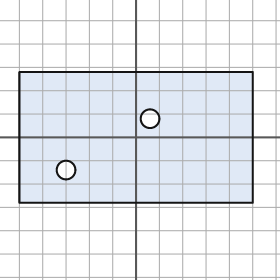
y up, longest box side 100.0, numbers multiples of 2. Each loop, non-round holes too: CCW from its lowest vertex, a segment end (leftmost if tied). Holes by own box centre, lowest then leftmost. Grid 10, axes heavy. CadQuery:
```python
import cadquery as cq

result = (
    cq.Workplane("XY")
    .moveTo(-50.0, -28.0)
    .lineTo(50.0, -28.0)
    .lineTo(50.0, 28.0)
    .lineTo(-50.0, 28.0)
    .close()
    .moveTo(-30.0, -14.0)
    .circle(4.0)
    .moveTo(6.0, 8.0)
    .circle(4.0)
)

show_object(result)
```